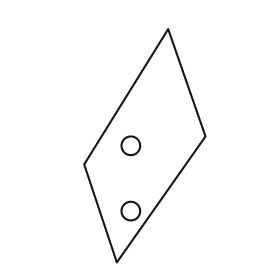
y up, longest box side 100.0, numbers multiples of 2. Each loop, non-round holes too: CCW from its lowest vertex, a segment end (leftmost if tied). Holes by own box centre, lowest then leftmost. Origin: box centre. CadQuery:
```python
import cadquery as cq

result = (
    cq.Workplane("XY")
    .moveTo(-12.0, -50.0)
    .lineTo(26.0, 4.0)
    .lineTo(10.0, 50.0)
    .lineTo(-26.0, -8.0)
    .close()
    .moveTo(-6.0, -28.0)
    .circle(4.0)
    .moveTo(-6.0, 0.0)
    .circle(4.0)
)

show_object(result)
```